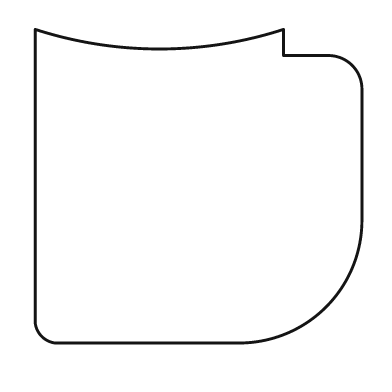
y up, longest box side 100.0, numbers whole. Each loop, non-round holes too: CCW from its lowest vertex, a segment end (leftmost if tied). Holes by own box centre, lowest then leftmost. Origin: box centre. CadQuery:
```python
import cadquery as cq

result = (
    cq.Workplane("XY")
    .moveTo(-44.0, -48.0)
    .lineTo(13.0, -48.0)
    .threePointArc((39.0, -37.0), (50.0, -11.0))
    .lineTo(50.0, 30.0)
    .threePointArc((47.0, 37.0), (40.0, 40.0))
    .lineTo(26.0, 40.0)
    .lineTo(26.0, 48.0)
    .threePointArc((-12.0, 42.0), (-50.0, 48.0))
    .lineTo(-50.0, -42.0)
    .threePointArc((-48.0, -46.0), (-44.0, -48.0))
    .close()
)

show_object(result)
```